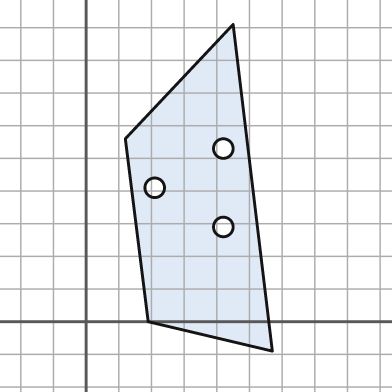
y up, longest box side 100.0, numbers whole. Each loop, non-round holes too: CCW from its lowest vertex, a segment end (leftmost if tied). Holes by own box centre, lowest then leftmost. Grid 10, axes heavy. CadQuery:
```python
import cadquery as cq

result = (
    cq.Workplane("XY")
    .moveTo(57.0, -9.0)
    .lineTo(45.0, 91.0)
    .lineTo(12.0, 56.0)
    .lineTo(19.0, 0.0)
    .close()
    .moveTo(42.0, 29.0)
    .circle(3.0)
    .moveTo(21.0, 41.0)
    .circle(3.0)
    .moveTo(42.0, 53.0)
    .circle(3.0)
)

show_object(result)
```